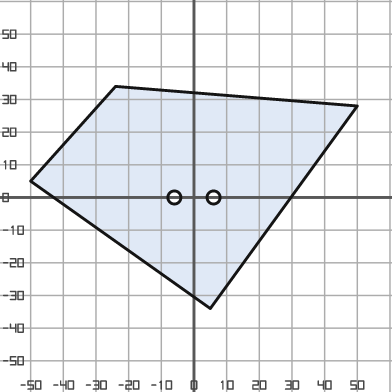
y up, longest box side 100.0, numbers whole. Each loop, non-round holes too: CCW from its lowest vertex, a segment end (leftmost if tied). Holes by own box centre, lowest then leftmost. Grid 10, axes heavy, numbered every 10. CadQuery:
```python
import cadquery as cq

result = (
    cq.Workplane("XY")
    .moveTo(5.0, -34.0)
    .lineTo(50.0, 28.0)
    .lineTo(-24.0, 34.0)
    .lineTo(-50.0, 5.0)
    .close()
    .moveTo(-6.0, 0.0)
    .circle(2.0)
    .moveTo(6.0, 0.0)
    .circle(2.0)
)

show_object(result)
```